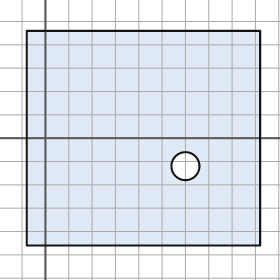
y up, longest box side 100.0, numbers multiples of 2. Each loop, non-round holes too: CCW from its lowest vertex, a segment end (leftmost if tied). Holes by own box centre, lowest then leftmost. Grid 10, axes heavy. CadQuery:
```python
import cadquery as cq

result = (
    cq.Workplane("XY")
    .moveTo(-8.0, -46.0)
    .lineTo(92.0, -46.0)
    .lineTo(92.0, 46.0)
    .lineTo(-8.0, 46.0)
    .close()
    .moveTo(60.0, -12.0)
    .circle(6.0)
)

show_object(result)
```